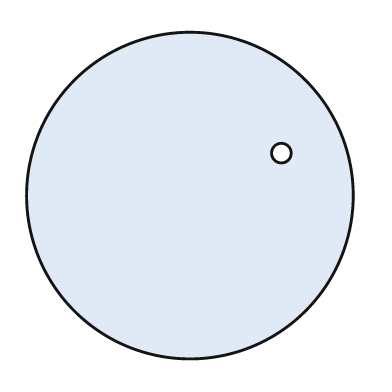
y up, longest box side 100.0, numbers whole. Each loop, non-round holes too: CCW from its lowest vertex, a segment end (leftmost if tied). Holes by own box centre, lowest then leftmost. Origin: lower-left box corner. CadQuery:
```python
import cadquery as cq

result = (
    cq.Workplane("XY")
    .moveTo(50.0, 50.0)
    .circle(50.0)
    .moveTo(78.0, 63.0)
    .circle(3.0)
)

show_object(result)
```